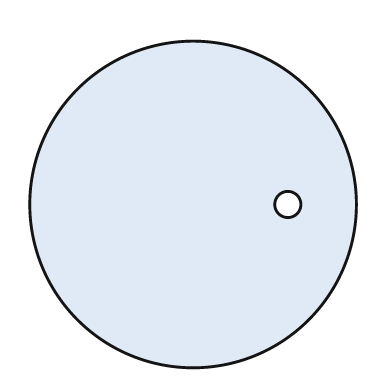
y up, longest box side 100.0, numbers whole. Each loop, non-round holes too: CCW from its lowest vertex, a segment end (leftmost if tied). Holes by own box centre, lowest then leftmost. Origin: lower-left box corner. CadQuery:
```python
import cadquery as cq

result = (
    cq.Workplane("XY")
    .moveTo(50.0, 50.0)
    .circle(50.0)
    .moveTo(79.0, 50.0)
    .circle(4.0)
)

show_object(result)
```